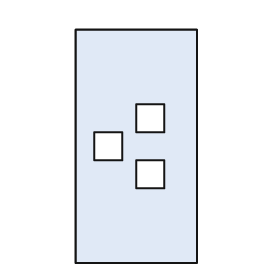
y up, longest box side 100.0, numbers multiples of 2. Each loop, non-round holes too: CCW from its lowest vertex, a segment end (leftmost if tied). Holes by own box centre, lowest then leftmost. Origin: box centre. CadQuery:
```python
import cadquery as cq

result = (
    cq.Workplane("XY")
    .moveTo(-26.0, -50.0)
    .lineTo(26.0, -50.0)
    .lineTo(26.0, 50.0)
    .lineTo(-26.0, 50.0)
    .close()
    .moveTo(0.0, -18.0)
    .lineTo(12.0, -18.0)
    .lineTo(12.0, -6.0)
    .lineTo(0.0, -6.0)
    .close()
    .moveTo(-18.0, -6.0)
    .lineTo(-6.0, -6.0)
    .lineTo(-6.0, 6.0)
    .lineTo(-18.0, 6.0)
    .close()
    .moveTo(0.0, 6.0)
    .lineTo(12.0, 6.0)
    .lineTo(12.0, 18.0)
    .lineTo(0.0, 18.0)
    .close()
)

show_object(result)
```